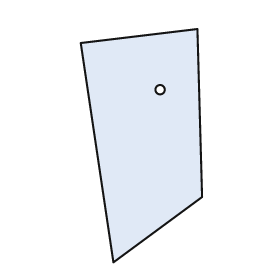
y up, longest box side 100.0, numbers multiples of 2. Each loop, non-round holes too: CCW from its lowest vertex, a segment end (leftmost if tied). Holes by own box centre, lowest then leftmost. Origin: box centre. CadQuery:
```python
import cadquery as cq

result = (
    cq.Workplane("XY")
    .moveTo(-12.0, -50.0)
    .lineTo(26.0, -22.0)
    .lineTo(24.0, 50.0)
    .lineTo(-26.0, 44.0)
    .close()
    .moveTo(8.0, 24.0)
    .circle(2.0)
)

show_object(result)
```